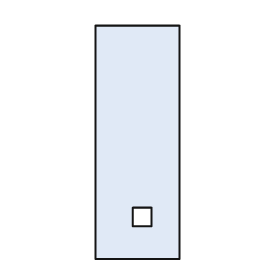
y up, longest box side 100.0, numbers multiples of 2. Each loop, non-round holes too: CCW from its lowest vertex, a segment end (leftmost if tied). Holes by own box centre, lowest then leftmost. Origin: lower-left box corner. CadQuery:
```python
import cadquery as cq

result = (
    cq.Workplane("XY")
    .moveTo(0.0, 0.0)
    .lineTo(36.0, 0.0)
    .lineTo(36.0, 100.0)
    .lineTo(0.0, 100.0)
    .close()
    .moveTo(16.0, 14.0)
    .lineTo(24.0, 14.0)
    .lineTo(24.0, 22.0)
    .lineTo(16.0, 22.0)
    .close()
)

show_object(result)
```